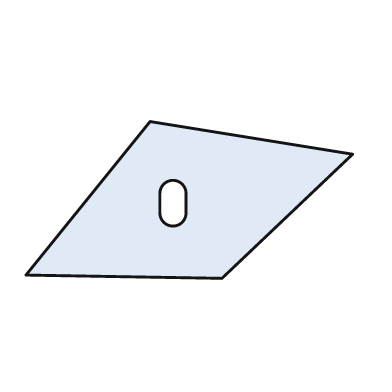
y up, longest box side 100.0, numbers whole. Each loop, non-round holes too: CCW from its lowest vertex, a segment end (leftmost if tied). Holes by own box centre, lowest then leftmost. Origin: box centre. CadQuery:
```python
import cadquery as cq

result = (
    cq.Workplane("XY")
    .moveTo(10.0, -24.0)
    .lineTo(50.0, 14.0)
    .lineTo(-12.0, 24.0)
    .lineTo(-50.0, -23.0)
    .close()
    .moveTo(-9.0, -4.0)
    .threePointArc((-5.0, -8.0), (-1.0, -4.0))
    .lineTo(-1.0, 2.0)
    .threePointArc((-5.0, 6.0), (-9.0, 2.0))
    .close()
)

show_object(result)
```